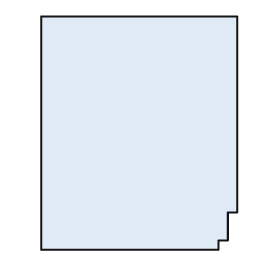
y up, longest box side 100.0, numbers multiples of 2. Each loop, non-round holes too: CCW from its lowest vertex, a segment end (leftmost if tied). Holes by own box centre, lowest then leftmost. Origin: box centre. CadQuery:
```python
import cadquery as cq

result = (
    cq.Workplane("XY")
    .moveTo(-42.0, -50.0)
    .lineTo(34.0, -50.0)
    .lineTo(34.0, -46.0)
    .lineTo(38.0, -46.0)
    .lineTo(38.0, -34.0)
    .lineTo(42.0, -34.0)
    .lineTo(42.0, 50.0)
    .lineTo(-42.0, 50.0)
    .close()
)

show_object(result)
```